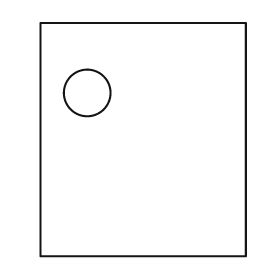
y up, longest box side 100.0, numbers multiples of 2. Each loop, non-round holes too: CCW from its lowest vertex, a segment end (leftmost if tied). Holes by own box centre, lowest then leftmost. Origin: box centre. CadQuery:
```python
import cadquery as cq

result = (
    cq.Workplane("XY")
    .moveTo(-44.0, -50.0)
    .lineTo(44.0, -50.0)
    .lineTo(44.0, 50.0)
    .lineTo(-44.0, 50.0)
    .close()
    .moveTo(-24.0, 20.0)
    .circle(10.0)
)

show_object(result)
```